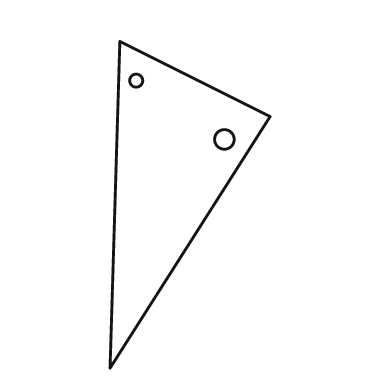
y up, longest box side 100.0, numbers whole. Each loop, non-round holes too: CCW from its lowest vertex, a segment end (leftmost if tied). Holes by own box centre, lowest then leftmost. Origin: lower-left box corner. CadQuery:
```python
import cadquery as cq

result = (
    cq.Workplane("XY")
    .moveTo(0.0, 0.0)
    .lineTo(49.0, 77.0)
    .lineTo(3.0, 100.0)
    .close()
    .moveTo(35.0, 70.0)
    .circle(3.0)
    .moveTo(8.0, 88.0)
    .circle(2.0)
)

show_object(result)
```